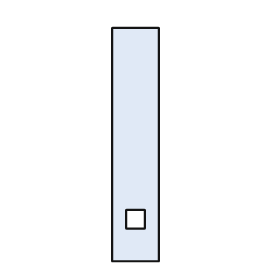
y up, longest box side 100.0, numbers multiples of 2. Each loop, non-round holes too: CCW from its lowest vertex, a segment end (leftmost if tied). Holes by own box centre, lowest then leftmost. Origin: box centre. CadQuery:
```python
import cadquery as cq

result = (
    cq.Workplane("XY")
    .moveTo(-10.0, -50.0)
    .lineTo(10.0, -50.0)
    .lineTo(10.0, 50.0)
    .lineTo(-10.0, 50.0)
    .close()
    .moveTo(-4.0, -36.0)
    .lineTo(4.0, -36.0)
    .lineTo(4.0, -28.0)
    .lineTo(-4.0, -28.0)
    .close()
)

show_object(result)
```